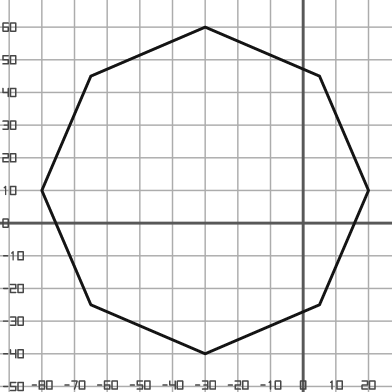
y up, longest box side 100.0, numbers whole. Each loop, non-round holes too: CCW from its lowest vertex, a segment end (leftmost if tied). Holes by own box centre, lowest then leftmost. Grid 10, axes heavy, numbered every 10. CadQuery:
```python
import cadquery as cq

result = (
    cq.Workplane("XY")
    .moveTo(-30.0, -40.0)
    .lineTo(5.0, -25.0)
    .lineTo(20.0, 10.0)
    .lineTo(5.0, 45.0)
    .lineTo(-30.0, 60.0)
    .lineTo(-65.0, 45.0)
    .lineTo(-80.0, 10.0)
    .lineTo(-65.0, -25.0)
    .close()
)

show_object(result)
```